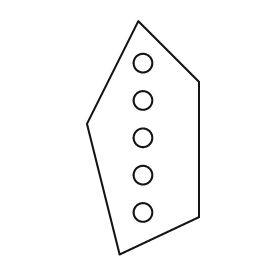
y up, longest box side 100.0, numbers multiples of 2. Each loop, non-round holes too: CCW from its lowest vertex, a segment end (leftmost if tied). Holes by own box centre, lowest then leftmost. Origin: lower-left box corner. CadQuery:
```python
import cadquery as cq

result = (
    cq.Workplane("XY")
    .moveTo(14.0, 0.0)
    .lineTo(48.0, 16.0)
    .lineTo(48.0, 74.0)
    .lineTo(22.0, 100.0)
    .lineTo(0.0, 56.0)
    .close()
    .moveTo(24.0, 18.0)
    .circle(4.0)
    .moveTo(24.0, 34.0)
    .circle(4.0)
    .moveTo(24.0, 50.0)
    .circle(4.0)
    .moveTo(24.0, 66.0)
    .circle(4.0)
    .moveTo(24.0, 82.0)
    .circle(4.0)
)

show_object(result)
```